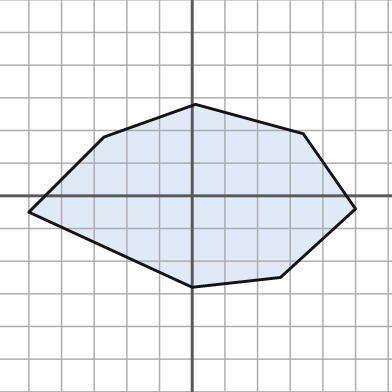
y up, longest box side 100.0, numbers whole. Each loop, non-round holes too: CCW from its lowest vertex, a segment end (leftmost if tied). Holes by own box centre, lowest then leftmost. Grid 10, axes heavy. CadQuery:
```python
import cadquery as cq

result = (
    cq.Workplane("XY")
    .moveTo(0.0, -28.0)
    .lineTo(27.0, -25.0)
    .lineTo(50.0, -4.0)
    .lineTo(34.0, 19.0)
    .lineTo(1.0, 28.0)
    .lineTo(-27.0, 18.0)
    .lineTo(-50.0, -5.0)
    .close()
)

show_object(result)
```